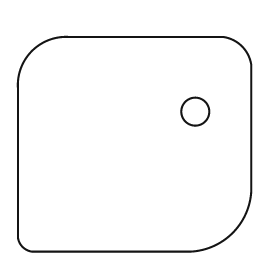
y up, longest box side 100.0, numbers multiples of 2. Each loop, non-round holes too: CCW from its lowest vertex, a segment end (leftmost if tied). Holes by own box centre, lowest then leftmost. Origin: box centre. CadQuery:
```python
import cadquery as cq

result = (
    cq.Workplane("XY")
    .moveTo(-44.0, -46.0)
    .lineTo(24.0, -46.0)
    .threePointArc((42.0, -38.0), (50.0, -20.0))
    .lineTo(50.0, 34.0)
    .threePointArc((46.0, 42.0), (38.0, 46.0))
    .lineTo(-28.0, 46.0)
    .threePointArc((-44.0, 40.0), (-50.0, 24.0))
    .lineTo(-50.0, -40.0)
    .threePointArc((-48.0, -44.0), (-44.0, -46.0))
    .close()
    .moveTo(26.0, 14.0)
    .circle(6.0)
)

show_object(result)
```